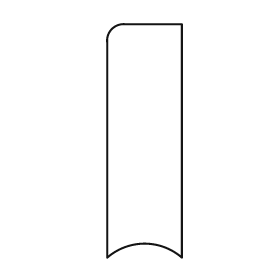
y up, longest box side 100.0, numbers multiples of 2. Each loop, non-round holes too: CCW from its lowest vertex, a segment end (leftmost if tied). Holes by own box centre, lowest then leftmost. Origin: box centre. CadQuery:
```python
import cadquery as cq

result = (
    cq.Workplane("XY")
    .moveTo(-16.0, -50.0)
    .threePointArc((0.0, -44.0), (16.0, -50.0))
    .lineTo(16.0, 50.0)
    .lineTo(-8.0, 50.0)
    .threePointArc((-14.0, 48.0), (-16.0, 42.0))
    .close()
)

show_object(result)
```